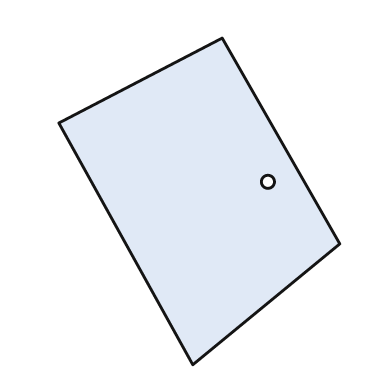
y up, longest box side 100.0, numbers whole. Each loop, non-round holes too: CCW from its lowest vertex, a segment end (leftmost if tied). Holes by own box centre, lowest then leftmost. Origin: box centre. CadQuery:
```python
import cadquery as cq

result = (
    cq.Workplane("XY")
    .moveTo(-2.0, -50.0)
    .lineTo(43.0, -13.0)
    .lineTo(7.0, 50.0)
    .lineTo(-43.0, 24.0)
    .close()
    .moveTo(21.0, 6.0)
    .circle(2.0)
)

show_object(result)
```